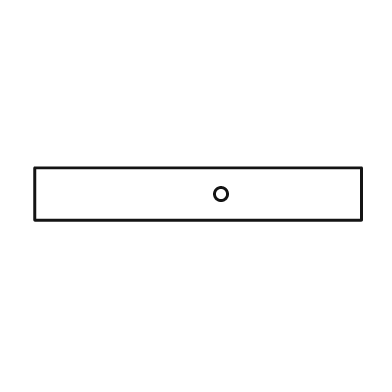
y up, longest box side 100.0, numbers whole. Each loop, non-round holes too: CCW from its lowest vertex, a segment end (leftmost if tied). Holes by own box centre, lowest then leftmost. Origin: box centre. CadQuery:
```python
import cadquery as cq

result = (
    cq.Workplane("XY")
    .moveTo(-50.0, -8.0)
    .lineTo(50.0, -8.0)
    .lineTo(50.0, 8.0)
    .lineTo(-50.0, 8.0)
    .close()
    .moveTo(7.0, 0.0)
    .circle(2.0)
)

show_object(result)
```